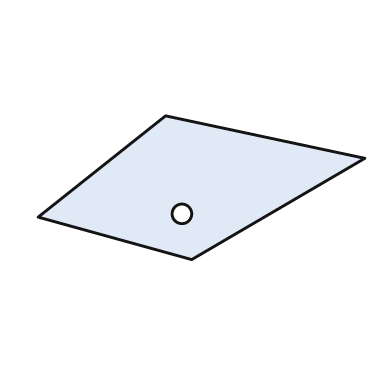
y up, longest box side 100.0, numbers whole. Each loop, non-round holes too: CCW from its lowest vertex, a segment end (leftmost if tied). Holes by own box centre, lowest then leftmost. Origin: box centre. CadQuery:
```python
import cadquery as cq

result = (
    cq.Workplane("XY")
    .moveTo(-3.0, -22.0)
    .lineTo(50.0, 9.0)
    .lineTo(-11.0, 22.0)
    .lineTo(-50.0, -9.0)
    .close()
    .moveTo(-6.0, -8.0)
    .circle(3.0)
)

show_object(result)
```